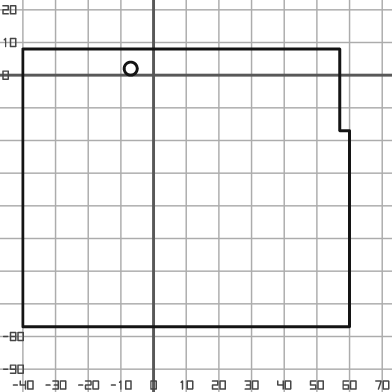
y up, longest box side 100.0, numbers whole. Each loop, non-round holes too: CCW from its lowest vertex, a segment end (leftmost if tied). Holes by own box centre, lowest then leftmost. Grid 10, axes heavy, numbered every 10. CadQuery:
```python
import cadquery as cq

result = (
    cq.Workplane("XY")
    .moveTo(-40.0, -77.0)
    .lineTo(60.0, -77.0)
    .lineTo(60.0, -17.0)
    .lineTo(57.0, -17.0)
    .lineTo(57.0, 8.0)
    .lineTo(-40.0, 8.0)
    .close()
    .moveTo(-7.0, 2.0)
    .circle(2.0)
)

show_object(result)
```